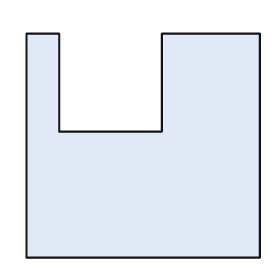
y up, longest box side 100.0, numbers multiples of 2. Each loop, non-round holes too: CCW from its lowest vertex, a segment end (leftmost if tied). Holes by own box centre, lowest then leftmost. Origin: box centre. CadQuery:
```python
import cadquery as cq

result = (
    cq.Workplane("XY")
    .moveTo(-50.0, -48.0)
    .lineTo(50.0, -48.0)
    .lineTo(50.0, 48.0)
    .lineTo(8.0, 48.0)
    .lineTo(8.0, 6.0)
    .lineTo(-36.0, 6.0)
    .lineTo(-36.0, 48.0)
    .lineTo(-50.0, 48.0)
    .close()
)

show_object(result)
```